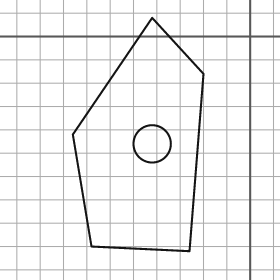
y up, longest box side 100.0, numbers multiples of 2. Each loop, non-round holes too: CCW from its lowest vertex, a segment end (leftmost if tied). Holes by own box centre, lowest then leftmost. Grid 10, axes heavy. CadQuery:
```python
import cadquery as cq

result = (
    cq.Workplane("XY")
    .moveTo(-26.0, -92.0)
    .lineTo(-20.0, -16.0)
    .lineTo(-42.0, 8.0)
    .lineTo(-76.0, -42.0)
    .lineTo(-68.0, -90.0)
    .close()
    .moveTo(-42.0, -46.0)
    .circle(8.0)
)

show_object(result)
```